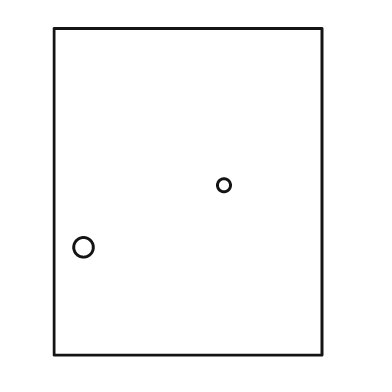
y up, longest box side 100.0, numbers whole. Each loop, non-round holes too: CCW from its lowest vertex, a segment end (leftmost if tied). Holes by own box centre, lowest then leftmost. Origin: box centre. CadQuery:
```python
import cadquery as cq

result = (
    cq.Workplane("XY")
    .moveTo(-41.0, -50.0)
    .lineTo(41.0, -50.0)
    .lineTo(41.0, 50.0)
    .lineTo(-41.0, 50.0)
    .close()
    .moveTo(-32.0, -17.0)
    .circle(3.0)
    .moveTo(11.0, 2.0)
    .circle(2.0)
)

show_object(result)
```